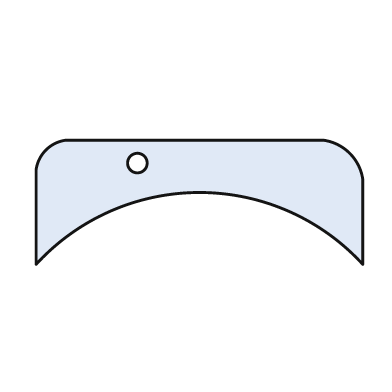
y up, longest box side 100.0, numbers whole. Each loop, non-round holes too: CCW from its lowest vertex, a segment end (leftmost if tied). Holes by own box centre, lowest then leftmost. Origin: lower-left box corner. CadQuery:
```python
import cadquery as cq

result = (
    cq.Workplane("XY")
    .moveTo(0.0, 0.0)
    .threePointArc((50.0, 22.0), (100.0, 0.0))
    .lineTo(100.0, 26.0)
    .threePointArc((96.0, 34.0), (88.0, 38.0))
    .lineTo(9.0, 38.0)
    .threePointArc((3.0, 35.0), (0.0, 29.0))
    .close()
    .moveTo(31.0, 31.0)
    .circle(3.0)
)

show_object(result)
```